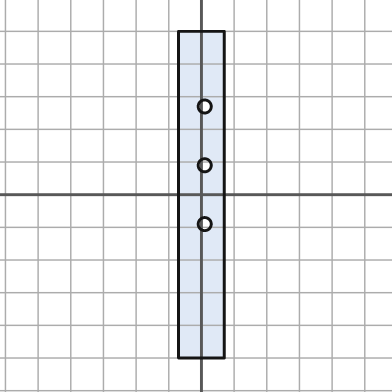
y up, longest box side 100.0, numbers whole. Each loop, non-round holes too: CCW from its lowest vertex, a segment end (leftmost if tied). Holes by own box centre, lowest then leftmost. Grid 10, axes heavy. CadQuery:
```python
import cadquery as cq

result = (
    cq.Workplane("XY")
    .moveTo(-7.0, -50.0)
    .lineTo(7.0, -50.0)
    .lineTo(7.0, 50.0)
    .lineTo(-7.0, 50.0)
    .close()
    .moveTo(1.0, -9.0)
    .circle(2.0)
    .moveTo(1.0, 9.0)
    .circle(2.0)
    .moveTo(1.0, 27.0)
    .circle(2.0)
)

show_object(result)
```